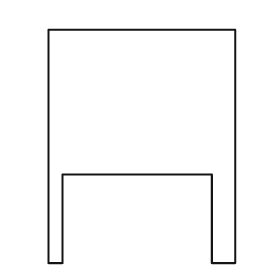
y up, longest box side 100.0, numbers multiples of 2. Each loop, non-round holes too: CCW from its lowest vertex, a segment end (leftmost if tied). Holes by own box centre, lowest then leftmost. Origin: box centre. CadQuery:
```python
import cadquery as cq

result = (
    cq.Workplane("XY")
    .moveTo(-40.0, -50.0)
    .lineTo(-34.0, -50.0)
    .lineTo(-34.0, -12.0)
    .lineTo(30.0, -12.0)
    .lineTo(30.0, -50.0)
    .lineTo(40.0, -50.0)
    .lineTo(40.0, 50.0)
    .lineTo(-40.0, 50.0)
    .close()
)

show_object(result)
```